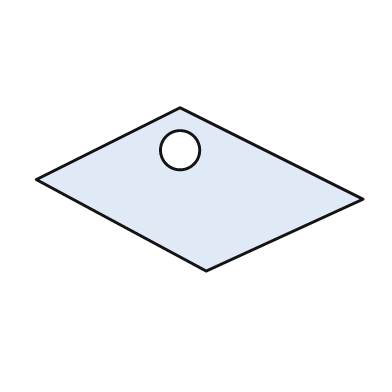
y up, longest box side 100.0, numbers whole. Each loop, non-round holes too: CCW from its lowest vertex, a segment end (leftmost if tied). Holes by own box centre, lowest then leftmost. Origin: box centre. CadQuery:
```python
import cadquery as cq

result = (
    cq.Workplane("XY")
    .moveTo(2.0, -25.0)
    .lineTo(50.0, -3.0)
    .lineTo(-6.0, 25.0)
    .lineTo(-50.0, 3.0)
    .close()
    .moveTo(-6.0, 12.0)
    .circle(6.0)
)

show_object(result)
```